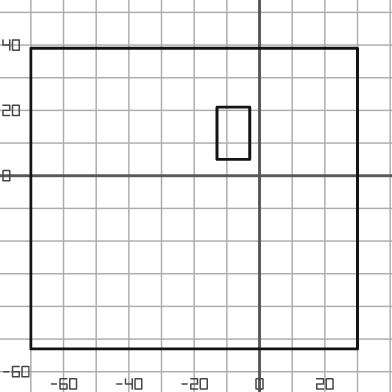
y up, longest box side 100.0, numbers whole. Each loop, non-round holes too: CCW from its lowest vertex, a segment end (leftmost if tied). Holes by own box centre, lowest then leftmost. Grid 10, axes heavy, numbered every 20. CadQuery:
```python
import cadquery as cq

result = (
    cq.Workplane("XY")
    .moveTo(-70.0, -53.0)
    .lineTo(30.0, -53.0)
    .lineTo(30.0, 39.0)
    .lineTo(-70.0, 39.0)
    .close()
    .moveTo(-13.0, 5.0)
    .lineTo(-3.0, 5.0)
    .lineTo(-3.0, 21.0)
    .lineTo(-13.0, 21.0)
    .close()
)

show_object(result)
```